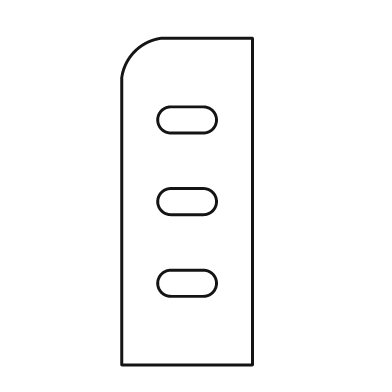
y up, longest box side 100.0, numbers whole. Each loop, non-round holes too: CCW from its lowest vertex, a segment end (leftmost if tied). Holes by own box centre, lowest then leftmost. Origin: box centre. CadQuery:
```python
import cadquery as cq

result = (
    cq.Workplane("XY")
    .moveTo(-20.0, -50.0)
    .lineTo(20.0, -50.0)
    .lineTo(20.0, 50.0)
    .lineTo(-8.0, 50.0)
    .threePointArc((-16.0, 46.0), (-20.0, 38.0))
    .close()
    .moveTo(-5.0, -29.0)
    .lineTo(5.0, -29.0)
    .threePointArc((9.0, -25.0), (5.0, -21.0))
    .lineTo(-5.0, -21.0)
    .threePointArc((-9.0, -25.0), (-5.0, -29.0))
    .close()
    .moveTo(-5.0, -4.0)
    .lineTo(5.0, -4.0)
    .threePointArc((9.0, 0.0), (5.0, 4.0))
    .lineTo(-5.0, 4.0)
    .threePointArc((-9.0, 0.0), (-5.0, -4.0))
    .close()
    .moveTo(-5.0, 21.0)
    .lineTo(5.0, 21.0)
    .threePointArc((9.0, 25.0), (5.0, 29.0))
    .lineTo(-5.0, 29.0)
    .threePointArc((-9.0, 25.0), (-5.0, 21.0))
    .close()
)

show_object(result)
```